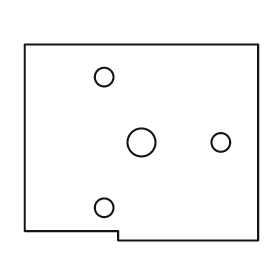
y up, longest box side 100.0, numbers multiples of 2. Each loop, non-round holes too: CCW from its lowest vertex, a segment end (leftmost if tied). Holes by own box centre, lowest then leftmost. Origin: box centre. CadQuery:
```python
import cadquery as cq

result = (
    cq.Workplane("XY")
    .moveTo(-10.0, -42.0)
    .lineTo(50.0, -42.0)
    .lineTo(50.0, 42.0)
    .lineTo(-50.0, 42.0)
    .lineTo(-50.0, -38.0)
    .lineTo(-10.0, -38.0)
    .close()
    .moveTo(-16.0, -28.0)
    .circle(4.0)
    .moveTo(0.0, 0.0)
    .circle(6.0)
    .moveTo(34.0, 0.0)
    .circle(4.0)
    .moveTo(-16.0, 28.0)
    .circle(4.0)
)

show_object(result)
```